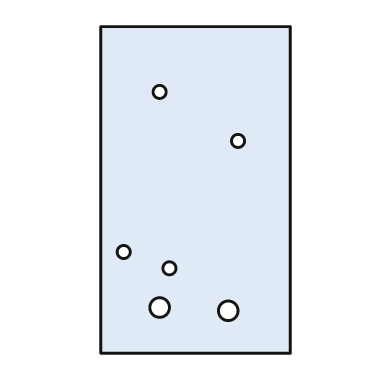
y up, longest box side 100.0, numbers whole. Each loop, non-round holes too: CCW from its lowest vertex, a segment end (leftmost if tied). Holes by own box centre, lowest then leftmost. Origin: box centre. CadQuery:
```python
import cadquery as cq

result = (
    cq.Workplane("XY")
    .moveTo(-29.0, -50.0)
    .lineTo(29.0, -50.0)
    .lineTo(29.0, 50.0)
    .lineTo(-29.0, 50.0)
    .close()
    .moveTo(10.0, -37.0)
    .circle(3.0)
    .moveTo(-11.0, -36.0)
    .circle(3.0)
    .moveTo(-8.0, -24.0)
    .circle(2.0)
    .moveTo(-22.0, -19.0)
    .circle(2.0)
    .moveTo(13.0, 15.0)
    .circle(2.0)
    .moveTo(-11.0, 30.0)
    .circle(2.0)
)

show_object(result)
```